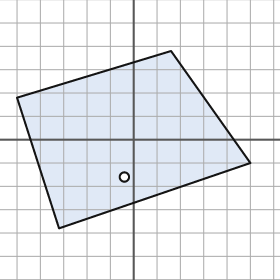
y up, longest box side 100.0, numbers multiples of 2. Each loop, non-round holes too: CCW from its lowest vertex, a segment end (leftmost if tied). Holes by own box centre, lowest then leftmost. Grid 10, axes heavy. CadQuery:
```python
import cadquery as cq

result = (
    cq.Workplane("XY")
    .moveTo(-32.0, -38.0)
    .lineTo(50.0, -10.0)
    .lineTo(16.0, 38.0)
    .lineTo(-50.0, 18.0)
    .close()
    .moveTo(-4.0, -16.0)
    .circle(2.0)
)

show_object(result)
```